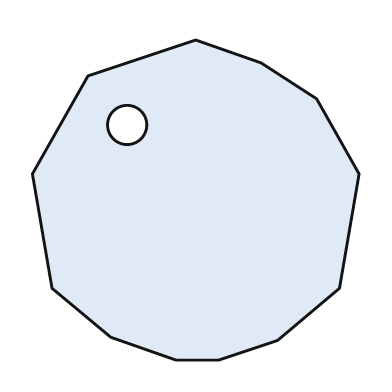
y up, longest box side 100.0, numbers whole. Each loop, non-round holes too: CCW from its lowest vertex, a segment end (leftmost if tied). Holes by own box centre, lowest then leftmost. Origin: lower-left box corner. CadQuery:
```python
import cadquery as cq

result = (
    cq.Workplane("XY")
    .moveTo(44.0, 0.0)
    .lineTo(57.0, 0.0)
    .lineTo(75.0, 6.0)
    .lineTo(94.0, 22.0)
    .lineTo(100.0, 57.0)
    .lineTo(87.0, 80.0)
    .lineTo(70.0, 91.0)
    .lineTo(50.0, 98.0)
    .lineTo(17.0, 87.0)
    .lineTo(0.0, 57.0)
    .lineTo(6.0, 22.0)
    .lineTo(24.0, 7.0)
    .close()
    .moveTo(29.0, 72.0)
    .circle(6.0)
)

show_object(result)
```